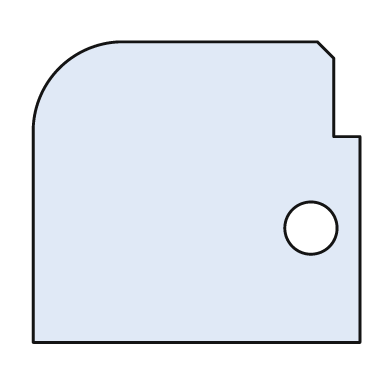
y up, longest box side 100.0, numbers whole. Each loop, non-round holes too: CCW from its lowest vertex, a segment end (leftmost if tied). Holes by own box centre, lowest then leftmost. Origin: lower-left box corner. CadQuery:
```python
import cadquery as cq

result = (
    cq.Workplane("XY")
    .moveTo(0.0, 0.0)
    .lineTo(100.0, 0.0)
    .lineTo(100.0, 63.0)
    .lineTo(92.0, 63.0)
    .lineTo(92.0, 87.0)
    .lineTo(87.0, 92.0)
    .lineTo(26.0, 92.0)
    .threePointArc((8.0, 84.0), (0.0, 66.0))
    .close()
    .moveTo(85.0, 35.0)
    .circle(8.0)
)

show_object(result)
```